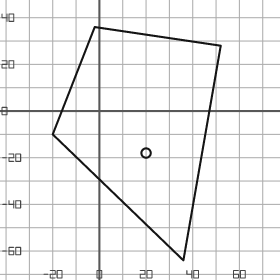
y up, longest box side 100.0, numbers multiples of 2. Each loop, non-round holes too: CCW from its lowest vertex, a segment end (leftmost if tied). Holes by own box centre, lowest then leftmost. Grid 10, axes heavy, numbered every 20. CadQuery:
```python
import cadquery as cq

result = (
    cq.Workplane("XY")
    .moveTo(36.0, -64.0)
    .lineTo(52.0, 28.0)
    .lineTo(-2.0, 36.0)
    .lineTo(-20.0, -10.0)
    .close()
    .moveTo(20.0, -18.0)
    .circle(2.0)
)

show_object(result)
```